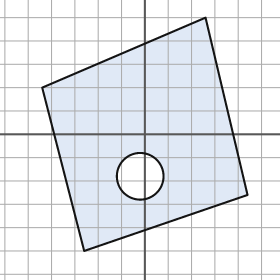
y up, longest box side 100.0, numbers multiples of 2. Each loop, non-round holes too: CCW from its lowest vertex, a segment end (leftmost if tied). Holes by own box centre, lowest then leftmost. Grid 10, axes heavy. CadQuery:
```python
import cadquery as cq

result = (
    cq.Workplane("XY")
    .moveTo(-26.0, -50.0)
    .lineTo(44.0, -26.0)
    .lineTo(26.0, 50.0)
    .lineTo(-44.0, 20.0)
    .close()
    .moveTo(-2.0, -18.0)
    .circle(10.0)
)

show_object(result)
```